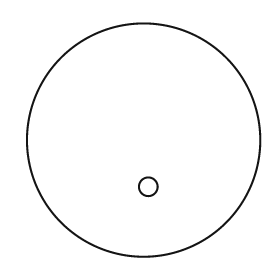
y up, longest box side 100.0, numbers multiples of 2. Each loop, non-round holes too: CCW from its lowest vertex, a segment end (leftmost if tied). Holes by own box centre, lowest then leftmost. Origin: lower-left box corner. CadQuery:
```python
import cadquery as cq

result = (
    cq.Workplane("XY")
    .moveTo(50.0, 50.0)
    .circle(50.0)
    .moveTo(52.0, 30.0)
    .circle(4.0)
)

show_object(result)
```